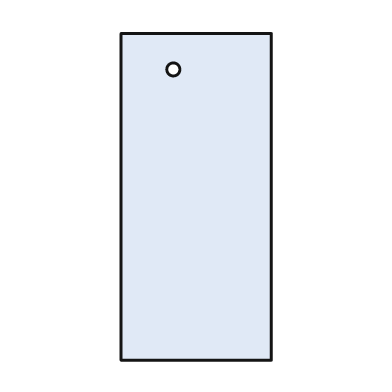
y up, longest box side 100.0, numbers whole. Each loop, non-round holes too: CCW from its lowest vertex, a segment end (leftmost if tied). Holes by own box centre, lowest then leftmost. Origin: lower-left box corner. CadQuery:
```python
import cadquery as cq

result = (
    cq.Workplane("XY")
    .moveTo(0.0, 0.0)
    .lineTo(46.0, 0.0)
    .lineTo(46.0, 100.0)
    .lineTo(0.0, 100.0)
    .close()
    .moveTo(16.0, 89.0)
    .circle(2.0)
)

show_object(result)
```